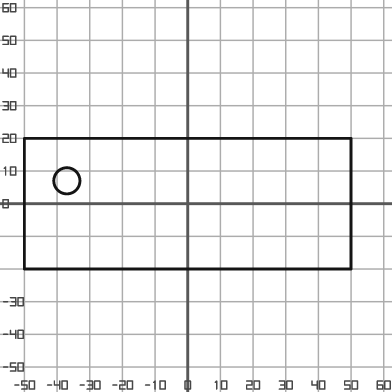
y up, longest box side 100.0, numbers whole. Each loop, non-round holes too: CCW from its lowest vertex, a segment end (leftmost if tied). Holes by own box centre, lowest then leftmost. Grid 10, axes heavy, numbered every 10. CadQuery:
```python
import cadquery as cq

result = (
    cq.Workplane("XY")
    .moveTo(-50.0, -20.0)
    .lineTo(50.0, -20.0)
    .lineTo(50.0, 20.0)
    .lineTo(-50.0, 20.0)
    .close()
    .moveTo(-37.0, 7.0)
    .circle(4.0)
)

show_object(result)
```